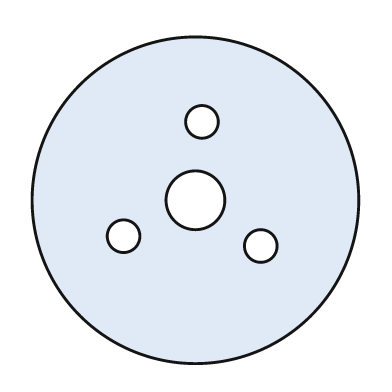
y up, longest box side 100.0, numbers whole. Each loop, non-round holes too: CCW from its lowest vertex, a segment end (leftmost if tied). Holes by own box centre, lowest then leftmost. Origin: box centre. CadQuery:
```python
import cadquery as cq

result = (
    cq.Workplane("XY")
    .moveTo(0.0, 0.0)
    .circle(50.0)
    .moveTo(20.0, -14.0)
    .circle(5.0)
    .moveTo(-22.0, -11.0)
    .circle(5.0)
    .moveTo(0.0, 0.0)
    .circle(9.0)
    .moveTo(2.0, 24.0)
    .circle(5.0)
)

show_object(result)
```